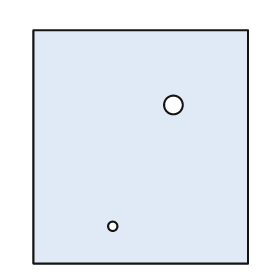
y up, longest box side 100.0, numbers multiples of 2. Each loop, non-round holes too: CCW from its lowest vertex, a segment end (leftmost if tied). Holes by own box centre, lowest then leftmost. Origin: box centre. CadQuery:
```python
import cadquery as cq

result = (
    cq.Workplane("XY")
    .moveTo(-46.0, -50.0)
    .lineTo(46.0, -50.0)
    .lineTo(46.0, 50.0)
    .lineTo(-46.0, 50.0)
    .close()
    .moveTo(-12.0, -34.0)
    .circle(2.0)
    .moveTo(14.0, 18.0)
    .circle(4.0)
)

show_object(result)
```